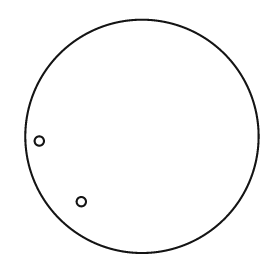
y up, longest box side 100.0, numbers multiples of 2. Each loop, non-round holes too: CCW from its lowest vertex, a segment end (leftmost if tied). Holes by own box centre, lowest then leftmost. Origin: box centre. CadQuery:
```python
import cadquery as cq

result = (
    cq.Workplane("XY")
    .moveTo(0.0, 0.0)
    .circle(50.0)
    .moveTo(-26.0, -28.0)
    .circle(2.0)
    .moveTo(-44.0, -2.0)
    .circle(2.0)
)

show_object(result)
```